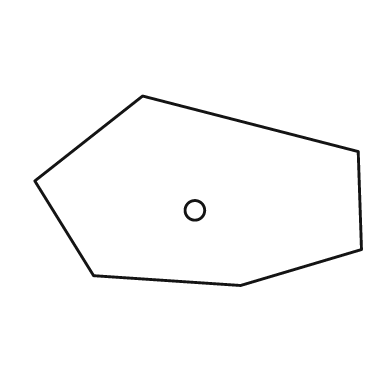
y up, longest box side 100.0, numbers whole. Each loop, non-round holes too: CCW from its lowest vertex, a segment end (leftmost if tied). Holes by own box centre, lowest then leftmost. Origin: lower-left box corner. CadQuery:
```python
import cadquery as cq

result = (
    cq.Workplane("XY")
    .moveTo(63.0, 0.0)
    .lineTo(100.0, 11.0)
    .lineTo(99.0, 41.0)
    .lineTo(33.0, 58.0)
    .lineTo(0.0, 32.0)
    .lineTo(18.0, 3.0)
    .close()
    .moveTo(49.0, 23.0)
    .circle(3.0)
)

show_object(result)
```